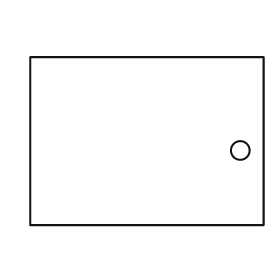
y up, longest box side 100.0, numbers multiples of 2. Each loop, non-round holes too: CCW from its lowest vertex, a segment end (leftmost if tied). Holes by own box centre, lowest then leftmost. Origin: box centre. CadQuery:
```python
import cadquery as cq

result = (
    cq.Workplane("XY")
    .moveTo(-50.0, -36.0)
    .lineTo(50.0, -36.0)
    .lineTo(50.0, 36.0)
    .lineTo(-50.0, 36.0)
    .close()
    .moveTo(40.0, -4.0)
    .circle(4.0)
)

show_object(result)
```